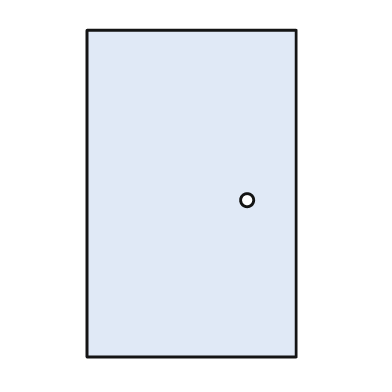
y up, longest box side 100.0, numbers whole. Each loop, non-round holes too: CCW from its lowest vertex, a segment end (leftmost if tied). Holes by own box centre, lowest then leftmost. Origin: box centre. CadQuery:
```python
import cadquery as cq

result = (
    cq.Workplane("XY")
    .moveTo(-32.0, -50.0)
    .lineTo(32.0, -50.0)
    .lineTo(32.0, 50.0)
    .lineTo(-32.0, 50.0)
    .close()
    .moveTo(17.0, -2.0)
    .circle(2.0)
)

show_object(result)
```